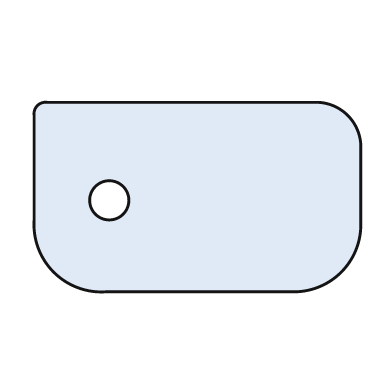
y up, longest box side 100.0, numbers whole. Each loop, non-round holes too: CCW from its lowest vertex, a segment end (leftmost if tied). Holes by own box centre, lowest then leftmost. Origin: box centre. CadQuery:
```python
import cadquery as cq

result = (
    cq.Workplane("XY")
    .moveTo(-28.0, -29.0)
    .lineTo(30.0, -29.0)
    .threePointArc((44.0, -23.0), (50.0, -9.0))
    .lineTo(50.0, 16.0)
    .threePointArc((46.0, 25.0), (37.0, 29.0))
    .lineTo(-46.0, 29.0)
    .threePointArc((-49.0, 28.0), (-50.0, 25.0))
    .lineTo(-50.0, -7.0)
    .threePointArc((-44.0, -23.0), (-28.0, -29.0))
    .close()
    .moveTo(-27.0, -1.0)
    .circle(6.0)
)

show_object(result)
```